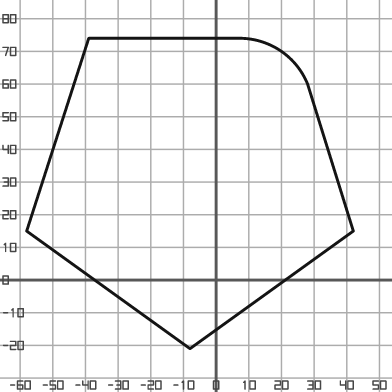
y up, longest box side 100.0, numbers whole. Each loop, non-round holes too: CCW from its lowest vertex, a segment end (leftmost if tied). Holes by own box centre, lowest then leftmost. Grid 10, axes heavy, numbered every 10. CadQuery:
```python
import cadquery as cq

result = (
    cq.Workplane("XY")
    .moveTo(-8.0, -21.0)
    .lineTo(42.0, 15.0)
    .lineTo(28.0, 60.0)
    .threePointArc((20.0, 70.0), (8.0, 74.0))
    .lineTo(-39.0, 74.0)
    .lineTo(-58.0, 15.0)
    .close()
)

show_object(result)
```